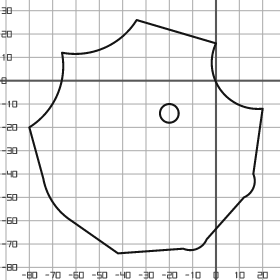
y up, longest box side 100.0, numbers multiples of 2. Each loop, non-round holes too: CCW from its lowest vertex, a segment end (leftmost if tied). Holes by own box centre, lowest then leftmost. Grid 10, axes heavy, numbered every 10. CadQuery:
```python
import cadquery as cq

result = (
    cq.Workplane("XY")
    .moveTo(-42.0, -74.0)
    .lineTo(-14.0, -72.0)
    .threePointArc((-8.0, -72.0), (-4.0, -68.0))
    .lineTo(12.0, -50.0)
    .threePointArc((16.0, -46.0), (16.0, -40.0))
    .lineTo(20.0, -12.0)
    .threePointArc((2.0, -4.0), (0.0, 16.0))
    .lineTo(-34.0, 26.0)
    .threePointArc((-48.0, 14.0), (-66.0, 12.0))
    .threePointArc((-68.0, -6.0), (-80.0, -20.0))
    .lineTo(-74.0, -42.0)
    .threePointArc((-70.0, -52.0), (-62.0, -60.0))
    .close()
    .moveTo(-20.0, -14.0)
    .circle(4.0)
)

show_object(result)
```